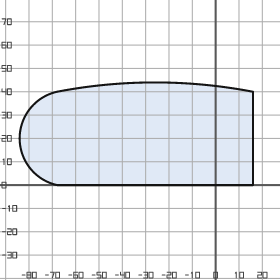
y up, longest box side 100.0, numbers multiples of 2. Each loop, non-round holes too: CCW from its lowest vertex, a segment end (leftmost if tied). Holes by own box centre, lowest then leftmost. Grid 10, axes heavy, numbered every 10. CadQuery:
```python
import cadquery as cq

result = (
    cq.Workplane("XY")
    .moveTo(-68.0, 0.0)
    .lineTo(16.0, 0.0)
    .lineTo(16.0, 40.0)
    .threePointArc((-26.0, 44.0), (-68.0, 40.0))
    .threePointArc((-84.0, 20.0), (-68.0, 0.0))
    .close()
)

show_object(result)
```